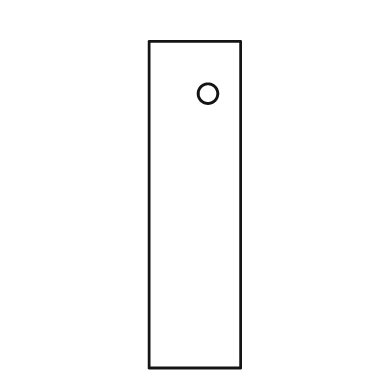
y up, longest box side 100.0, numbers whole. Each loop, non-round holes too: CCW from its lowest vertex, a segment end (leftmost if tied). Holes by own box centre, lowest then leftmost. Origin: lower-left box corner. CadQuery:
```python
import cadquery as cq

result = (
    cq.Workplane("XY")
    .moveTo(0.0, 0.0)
    .lineTo(28.0, 0.0)
    .lineTo(28.0, 100.0)
    .lineTo(0.0, 100.0)
    .close()
    .moveTo(18.0, 84.0)
    .circle(3.0)
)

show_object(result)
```